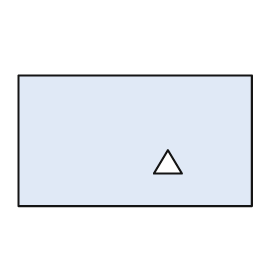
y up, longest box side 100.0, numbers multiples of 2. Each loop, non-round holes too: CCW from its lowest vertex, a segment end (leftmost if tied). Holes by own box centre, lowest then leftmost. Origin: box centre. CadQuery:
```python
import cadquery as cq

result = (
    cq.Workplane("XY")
    .moveTo(-50.0, -28.0)
    .lineTo(50.0, -28.0)
    .lineTo(50.0, 28.0)
    .lineTo(-50.0, 28.0)
    .close()
    .moveTo(8.0, -14.0)
    .lineTo(20.0, -14.0)
    .lineTo(14.0, -4.0)
    .close()
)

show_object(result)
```